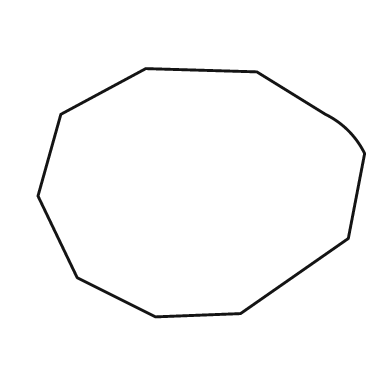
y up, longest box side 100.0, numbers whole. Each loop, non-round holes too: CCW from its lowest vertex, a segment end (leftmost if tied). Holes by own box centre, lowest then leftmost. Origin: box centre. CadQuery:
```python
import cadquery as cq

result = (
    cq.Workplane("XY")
    .moveTo(-14.0, -38.0)
    .lineTo(12.0, -37.0)
    .lineTo(45.0, -14.0)
    .lineTo(50.0, 12.0)
    .threePointArc((45.0, 19.0), (38.0, 24.0))
    .lineTo(17.0, 37.0)
    .lineTo(-17.0, 38.0)
    .lineTo(-43.0, 24.0)
    .lineTo(-50.0, -1.0)
    .lineTo(-38.0, -26.0)
    .close()
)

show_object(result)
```